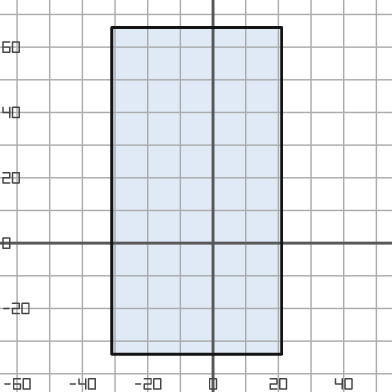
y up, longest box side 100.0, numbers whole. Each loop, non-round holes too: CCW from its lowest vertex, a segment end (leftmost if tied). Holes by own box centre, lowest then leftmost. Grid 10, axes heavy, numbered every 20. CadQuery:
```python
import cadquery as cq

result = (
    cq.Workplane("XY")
    .moveTo(-31.0, -34.0)
    .lineTo(21.0, -34.0)
    .lineTo(21.0, 66.0)
    .lineTo(-31.0, 66.0)
    .close()
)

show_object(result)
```